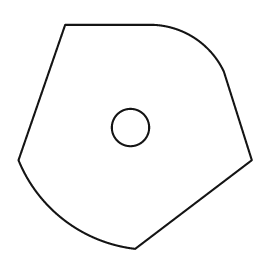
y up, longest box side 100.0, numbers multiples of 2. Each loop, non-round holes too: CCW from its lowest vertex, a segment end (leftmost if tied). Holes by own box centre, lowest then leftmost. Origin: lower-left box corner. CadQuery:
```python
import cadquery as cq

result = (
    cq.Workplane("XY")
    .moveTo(50.0, 0.0)
    .lineTo(100.0, 38.0)
    .lineTo(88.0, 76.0)
    .threePointArc((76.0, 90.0), (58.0, 96.0))
    .lineTo(20.0, 96.0)
    .lineTo(0.0, 38.0)
    .threePointArc((20.0, 12.0), (50.0, 0.0))
    .close()
    .moveTo(48.0, 52.0)
    .circle(8.0)
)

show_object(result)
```